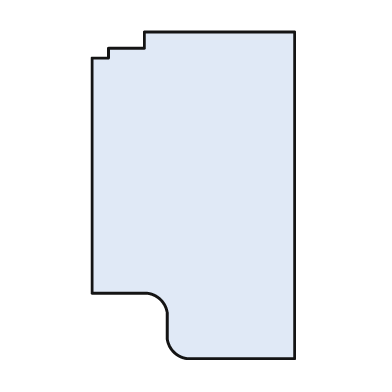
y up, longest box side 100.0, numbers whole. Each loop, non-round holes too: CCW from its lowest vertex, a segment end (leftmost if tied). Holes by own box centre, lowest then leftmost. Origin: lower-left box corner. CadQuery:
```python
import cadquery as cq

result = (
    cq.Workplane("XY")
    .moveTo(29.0, 0.0)
    .lineTo(62.0, 0.0)
    .lineTo(62.0, 100.0)
    .lineTo(16.0, 100.0)
    .lineTo(16.0, 95.0)
    .lineTo(5.0, 95.0)
    .lineTo(5.0, 92.0)
    .lineTo(0.0, 92.0)
    .lineTo(0.0, 20.0)
    .lineTo(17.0, 20.0)
    .threePointArc((21.0, 18.0), (23.0, 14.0))
    .lineTo(23.0, 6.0)
    .threePointArc((25.0, 2.0), (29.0, 0.0))
    .close()
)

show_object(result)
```